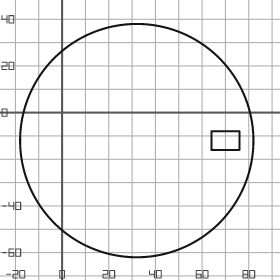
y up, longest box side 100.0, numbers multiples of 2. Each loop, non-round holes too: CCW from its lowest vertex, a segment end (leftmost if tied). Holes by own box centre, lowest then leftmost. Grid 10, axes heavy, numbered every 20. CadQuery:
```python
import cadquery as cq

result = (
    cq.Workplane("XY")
    .moveTo(32.0, -12.0)
    .circle(50.0)
    .moveTo(64.0, -16.0)
    .lineTo(76.0, -16.0)
    .lineTo(76.0, -8.0)
    .lineTo(64.0, -8.0)
    .close()
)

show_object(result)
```